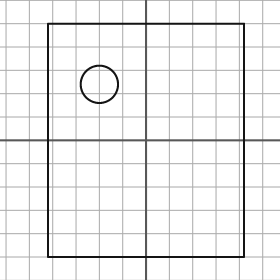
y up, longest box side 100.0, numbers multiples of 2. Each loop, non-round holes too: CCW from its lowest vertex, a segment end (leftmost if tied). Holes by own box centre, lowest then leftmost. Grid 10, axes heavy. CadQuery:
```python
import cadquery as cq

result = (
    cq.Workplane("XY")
    .moveTo(-42.0, -50.0)
    .lineTo(42.0, -50.0)
    .lineTo(42.0, 50.0)
    .lineTo(-42.0, 50.0)
    .close()
    .moveTo(-20.0, 24.0)
    .circle(8.0)
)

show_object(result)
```